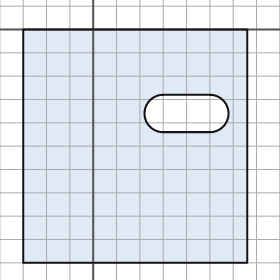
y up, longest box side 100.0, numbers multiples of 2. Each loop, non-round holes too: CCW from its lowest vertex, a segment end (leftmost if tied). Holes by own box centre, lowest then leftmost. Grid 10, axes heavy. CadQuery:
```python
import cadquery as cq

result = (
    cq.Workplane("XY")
    .moveTo(-30.0, -100.0)
    .lineTo(66.0, -100.0)
    .lineTo(66.0, 0.0)
    .lineTo(-30.0, 0.0)
    .close()
    .moveTo(30.0, -44.0)
    .lineTo(50.0, -44.0)
    .threePointArc((58.0, -36.0), (50.0, -28.0))
    .lineTo(30.0, -28.0)
    .threePointArc((22.0, -36.0), (30.0, -44.0))
    .close()
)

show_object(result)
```